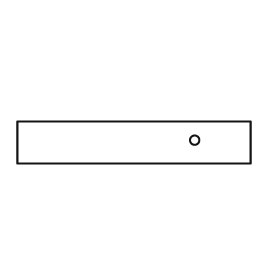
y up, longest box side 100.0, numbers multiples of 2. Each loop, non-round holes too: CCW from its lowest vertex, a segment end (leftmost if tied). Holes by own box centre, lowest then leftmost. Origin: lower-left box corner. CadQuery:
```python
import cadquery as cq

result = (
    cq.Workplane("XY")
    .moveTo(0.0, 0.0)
    .lineTo(100.0, 0.0)
    .lineTo(100.0, 18.0)
    .lineTo(0.0, 18.0)
    .close()
    .moveTo(76.0, 10.0)
    .circle(2.0)
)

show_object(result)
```